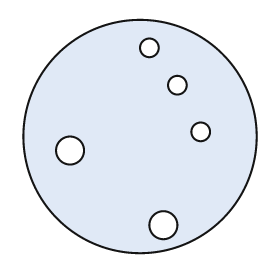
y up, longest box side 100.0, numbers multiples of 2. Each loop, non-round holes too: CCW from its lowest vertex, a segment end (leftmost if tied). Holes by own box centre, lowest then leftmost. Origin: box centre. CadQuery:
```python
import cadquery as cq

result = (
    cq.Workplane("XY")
    .moveTo(0.0, 0.0)
    .circle(50.0)
    .moveTo(10.0, -38.0)
    .circle(6.0)
    .moveTo(-30.0, -6.0)
    .circle(6.0)
    .moveTo(26.0, 2.0)
    .circle(4.0)
    .moveTo(16.0, 22.0)
    .circle(4.0)
    .moveTo(4.0, 38.0)
    .circle(4.0)
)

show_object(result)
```